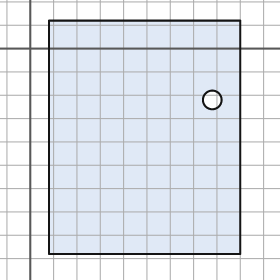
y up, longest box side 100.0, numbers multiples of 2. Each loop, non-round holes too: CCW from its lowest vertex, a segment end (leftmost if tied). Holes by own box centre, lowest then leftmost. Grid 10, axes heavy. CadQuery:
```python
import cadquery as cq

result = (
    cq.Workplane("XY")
    .moveTo(8.0, -88.0)
    .lineTo(90.0, -88.0)
    .lineTo(90.0, 12.0)
    .lineTo(8.0, 12.0)
    .close()
    .moveTo(78.0, -22.0)
    .circle(4.0)
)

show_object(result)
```